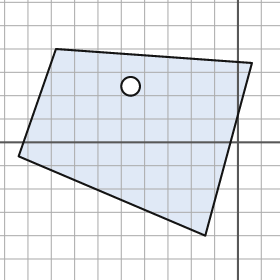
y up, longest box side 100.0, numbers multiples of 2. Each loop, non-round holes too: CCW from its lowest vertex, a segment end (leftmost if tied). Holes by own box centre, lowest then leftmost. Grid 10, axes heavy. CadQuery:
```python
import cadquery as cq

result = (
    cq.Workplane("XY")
    .moveTo(-14.0, -40.0)
    .lineTo(6.0, 34.0)
    .lineTo(-78.0, 40.0)
    .lineTo(-94.0, -6.0)
    .close()
    .moveTo(-46.0, 24.0)
    .circle(4.0)
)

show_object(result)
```